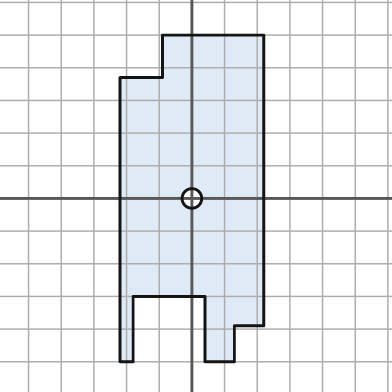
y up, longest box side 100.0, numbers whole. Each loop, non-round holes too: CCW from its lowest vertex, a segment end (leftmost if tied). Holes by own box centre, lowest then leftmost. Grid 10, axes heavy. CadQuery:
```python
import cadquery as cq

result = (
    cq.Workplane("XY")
    .moveTo(-22.0, -50.0)
    .lineTo(-18.0, -50.0)
    .lineTo(-18.0, -30.0)
    .lineTo(4.0, -30.0)
    .lineTo(4.0, -50.0)
    .lineTo(13.0, -50.0)
    .lineTo(13.0, -39.0)
    .lineTo(22.0, -39.0)
    .lineTo(22.0, 50.0)
    .lineTo(-9.0, 50.0)
    .lineTo(-9.0, 37.0)
    .lineTo(-22.0, 37.0)
    .close()
    .moveTo(0.0, 0.0)
    .circle(3.0)
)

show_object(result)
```